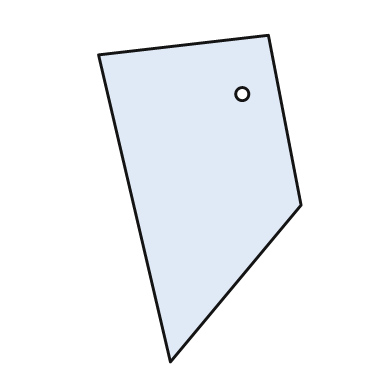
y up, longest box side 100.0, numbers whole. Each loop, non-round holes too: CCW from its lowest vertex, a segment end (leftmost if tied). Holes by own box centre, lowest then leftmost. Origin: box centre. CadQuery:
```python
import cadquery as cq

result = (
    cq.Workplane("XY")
    .moveTo(-9.0, -50.0)
    .lineTo(31.0, -2.0)
    .lineTo(21.0, 50.0)
    .lineTo(-31.0, 44.0)
    .close()
    .moveTo(13.0, 32.0)
    .circle(2.0)
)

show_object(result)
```